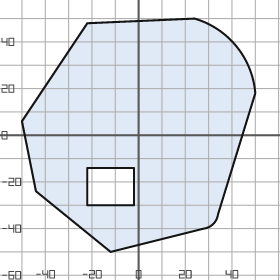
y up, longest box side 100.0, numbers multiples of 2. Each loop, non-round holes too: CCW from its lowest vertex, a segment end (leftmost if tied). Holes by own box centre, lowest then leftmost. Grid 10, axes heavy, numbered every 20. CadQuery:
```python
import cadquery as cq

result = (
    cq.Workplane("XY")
    .moveTo(-12.0, -50.0)
    .lineTo(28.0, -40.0)
    .threePointArc((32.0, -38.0), (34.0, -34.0))
    .lineTo(50.0, 18.0)
    .threePointArc((42.0, 38.0), (24.0, 50.0))
    .lineTo(-22.0, 48.0)
    .lineTo(-50.0, 6.0)
    .lineTo(-44.0, -24.0)
    .close()
    .moveTo(-22.0, -30.0)
    .lineTo(-2.0, -30.0)
    .lineTo(-2.0, -14.0)
    .lineTo(-22.0, -14.0)
    .close()
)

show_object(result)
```